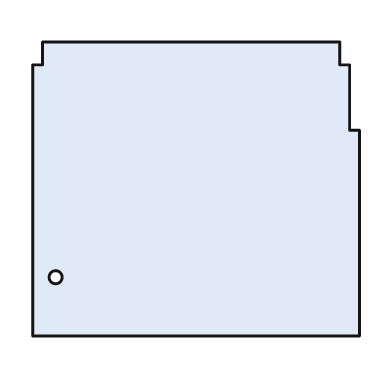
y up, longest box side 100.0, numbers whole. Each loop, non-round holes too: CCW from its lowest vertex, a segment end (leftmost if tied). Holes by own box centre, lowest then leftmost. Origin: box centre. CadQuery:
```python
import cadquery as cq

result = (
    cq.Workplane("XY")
    .moveTo(-50.0, -45.0)
    .lineTo(50.0, -45.0)
    .lineTo(50.0, 18.0)
    .lineTo(47.0, 18.0)
    .lineTo(47.0, 38.0)
    .lineTo(44.0, 38.0)
    .lineTo(44.0, 45.0)
    .lineTo(-47.0, 45.0)
    .lineTo(-47.0, 38.0)
    .lineTo(-50.0, 38.0)
    .close()
    .moveTo(-43.0, -27.0)
    .circle(2.0)
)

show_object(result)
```